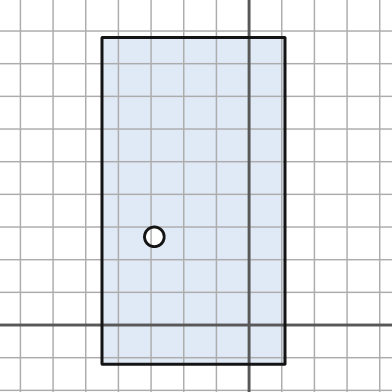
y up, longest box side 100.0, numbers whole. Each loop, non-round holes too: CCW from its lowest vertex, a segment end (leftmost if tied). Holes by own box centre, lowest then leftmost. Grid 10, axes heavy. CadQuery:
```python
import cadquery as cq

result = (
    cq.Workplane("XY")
    .moveTo(-45.0, -12.0)
    .lineTo(11.0, -12.0)
    .lineTo(11.0, 88.0)
    .lineTo(-45.0, 88.0)
    .close()
    .moveTo(-29.0, 27.0)
    .circle(3.0)
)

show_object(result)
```